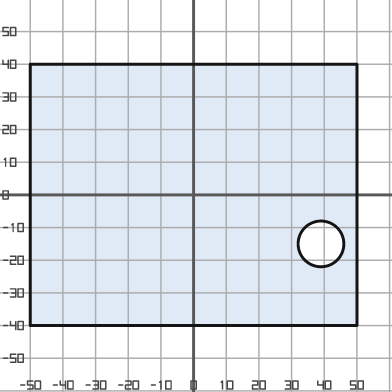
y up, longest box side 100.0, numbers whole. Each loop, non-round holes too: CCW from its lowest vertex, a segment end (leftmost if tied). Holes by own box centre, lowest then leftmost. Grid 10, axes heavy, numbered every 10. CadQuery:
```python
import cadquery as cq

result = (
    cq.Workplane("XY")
    .moveTo(-50.0, -40.0)
    .lineTo(50.0, -40.0)
    .lineTo(50.0, 40.0)
    .lineTo(-50.0, 40.0)
    .close()
    .moveTo(39.0, -15.0)
    .circle(7.0)
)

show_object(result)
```